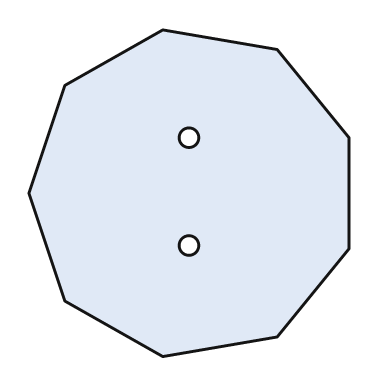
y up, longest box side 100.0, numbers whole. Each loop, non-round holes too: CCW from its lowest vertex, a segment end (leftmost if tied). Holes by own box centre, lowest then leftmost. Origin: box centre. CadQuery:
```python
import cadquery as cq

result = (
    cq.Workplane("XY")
    .moveTo(-8.0, -50.0)
    .lineTo(27.0, -44.0)
    .lineTo(49.0, -17.0)
    .lineTo(49.0, 17.0)
    .lineTo(27.0, 44.0)
    .lineTo(-8.0, 50.0)
    .lineTo(-38.0, 33.0)
    .lineTo(-49.0, 0.0)
    .lineTo(-38.0, -33.0)
    .close()
    .moveTo(0.0, -16.0)
    .circle(3.0)
    .moveTo(0.0, 17.0)
    .circle(3.0)
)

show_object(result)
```